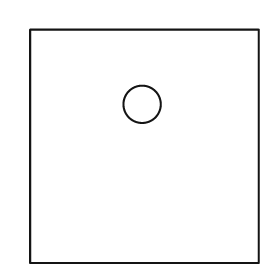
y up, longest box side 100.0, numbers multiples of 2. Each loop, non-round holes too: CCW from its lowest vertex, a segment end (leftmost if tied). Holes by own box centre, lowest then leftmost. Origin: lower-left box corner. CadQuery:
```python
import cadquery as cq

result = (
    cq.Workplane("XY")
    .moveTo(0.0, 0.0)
    .lineTo(98.0, 0.0)
    .lineTo(98.0, 100.0)
    .lineTo(0.0, 100.0)
    .close()
    .moveTo(48.0, 68.0)
    .circle(8.0)
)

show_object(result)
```